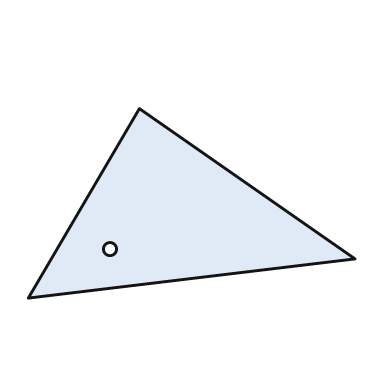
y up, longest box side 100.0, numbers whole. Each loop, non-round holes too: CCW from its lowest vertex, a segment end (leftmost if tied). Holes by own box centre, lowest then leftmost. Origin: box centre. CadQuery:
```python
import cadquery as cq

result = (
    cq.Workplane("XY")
    .moveTo(-50.0, -29.0)
    .lineTo(50.0, -17.0)
    .lineTo(-16.0, 29.0)
    .close()
    .moveTo(-25.0, -14.0)
    .circle(2.0)
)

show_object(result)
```